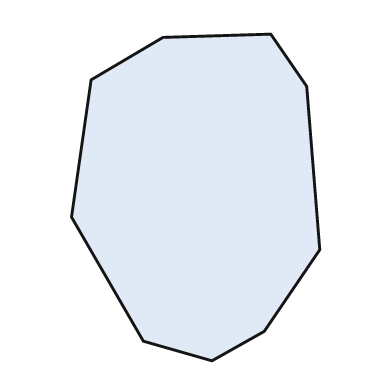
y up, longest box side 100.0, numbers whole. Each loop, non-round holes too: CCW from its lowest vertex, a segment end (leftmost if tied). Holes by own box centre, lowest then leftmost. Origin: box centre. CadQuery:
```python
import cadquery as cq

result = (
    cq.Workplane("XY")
    .moveTo(5.0, -50.0)
    .lineTo(21.0, -41.0)
    .lineTo(38.0, -16.0)
    .lineTo(34.0, 34.0)
    .lineTo(23.0, 50.0)
    .lineTo(-10.0, 49.0)
    .lineTo(-32.0, 36.0)
    .lineTo(-38.0, -6.0)
    .lineTo(-16.0, -44.0)
    .close()
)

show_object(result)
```